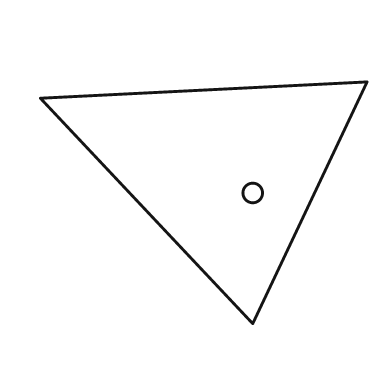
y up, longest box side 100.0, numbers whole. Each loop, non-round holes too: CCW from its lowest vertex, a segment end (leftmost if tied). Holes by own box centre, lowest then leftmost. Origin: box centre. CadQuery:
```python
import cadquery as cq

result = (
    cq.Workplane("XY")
    .moveTo(15.0, -37.0)
    .lineTo(50.0, 37.0)
    .lineTo(-50.0, 32.0)
    .close()
    .moveTo(15.0, 3.0)
    .circle(3.0)
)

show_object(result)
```